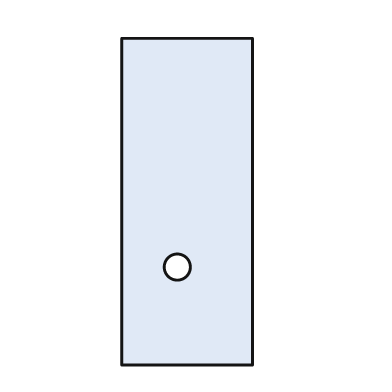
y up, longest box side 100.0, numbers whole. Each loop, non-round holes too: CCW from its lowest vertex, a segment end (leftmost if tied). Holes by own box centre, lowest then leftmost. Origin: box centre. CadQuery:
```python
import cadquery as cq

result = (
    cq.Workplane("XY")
    .moveTo(-20.0, -50.0)
    .lineTo(20.0, -50.0)
    .lineTo(20.0, 50.0)
    .lineTo(-20.0, 50.0)
    .close()
    .moveTo(-3.0, -20.0)
    .circle(4.0)
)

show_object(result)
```